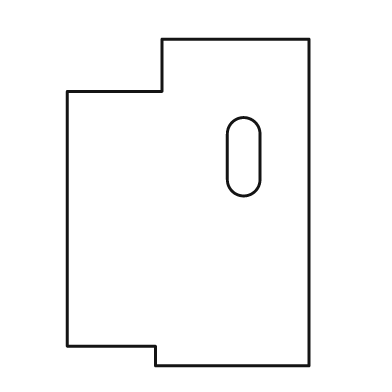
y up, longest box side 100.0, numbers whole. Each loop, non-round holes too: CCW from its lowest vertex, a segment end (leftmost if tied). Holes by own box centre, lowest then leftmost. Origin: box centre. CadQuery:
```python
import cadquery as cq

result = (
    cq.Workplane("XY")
    .moveTo(-10.0, -50.0)
    .lineTo(37.0, -50.0)
    .lineTo(37.0, 50.0)
    .lineTo(-8.0, 50.0)
    .lineTo(-8.0, 34.0)
    .lineTo(-37.0, 34.0)
    .lineTo(-37.0, -44.0)
    .lineTo(-10.0, -44.0)
    .close()
    .moveTo(12.0, 7.0)
    .threePointArc((17.0, 2.0), (22.0, 7.0))
    .lineTo(22.0, 21.0)
    .threePointArc((17.0, 26.0), (12.0, 21.0))
    .close()
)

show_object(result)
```